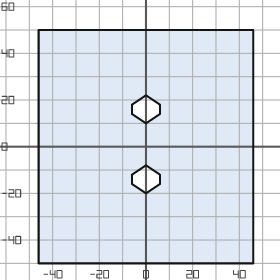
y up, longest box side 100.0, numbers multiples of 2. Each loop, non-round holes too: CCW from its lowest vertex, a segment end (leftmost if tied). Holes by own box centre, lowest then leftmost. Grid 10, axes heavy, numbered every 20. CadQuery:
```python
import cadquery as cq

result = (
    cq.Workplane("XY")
    .moveTo(-46.0, -50.0)
    .lineTo(46.0, -50.0)
    .lineTo(46.0, 50.0)
    .lineTo(-46.0, 50.0)
    .close()
    .moveTo(0.0, -20.0)
    .lineTo(6.0, -16.0)
    .lineTo(6.0, -12.0)
    .lineTo(0.0, -8.0)
    .lineTo(-6.0, -12.0)
    .lineTo(-6.0, -16.0)
    .close()
    .moveTo(0.0, 10.0)
    .lineTo(6.0, 14.0)
    .lineTo(6.0, 18.0)
    .lineTo(0.0, 22.0)
    .lineTo(-6.0, 18.0)
    .lineTo(-6.0, 14.0)
    .close()
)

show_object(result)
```